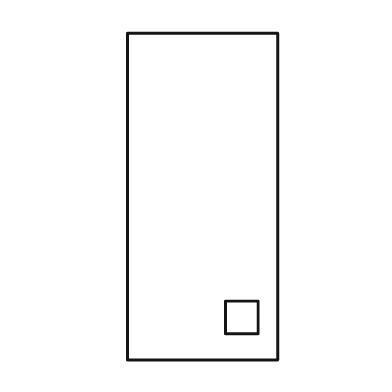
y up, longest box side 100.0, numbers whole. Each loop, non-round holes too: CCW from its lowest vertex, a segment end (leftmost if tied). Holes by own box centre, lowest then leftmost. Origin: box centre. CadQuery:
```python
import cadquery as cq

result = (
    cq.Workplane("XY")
    .moveTo(-23.0, -50.0)
    .lineTo(23.0, -50.0)
    .lineTo(23.0, 50.0)
    .lineTo(-23.0, 50.0)
    .close()
    .moveTo(7.0, -42.0)
    .lineTo(17.0, -42.0)
    .lineTo(17.0, -32.0)
    .lineTo(7.0, -32.0)
    .close()
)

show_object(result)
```